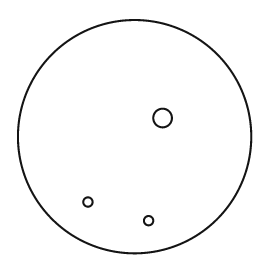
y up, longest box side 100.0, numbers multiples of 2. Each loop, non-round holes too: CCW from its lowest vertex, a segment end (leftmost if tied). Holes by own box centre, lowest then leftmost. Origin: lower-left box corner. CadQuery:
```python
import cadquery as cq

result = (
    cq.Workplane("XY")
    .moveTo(50.0, 50.0)
    .circle(50.0)
    .moveTo(56.0, 14.0)
    .circle(2.0)
    .moveTo(30.0, 22.0)
    .circle(2.0)
    .moveTo(62.0, 58.0)
    .circle(4.0)
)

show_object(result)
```